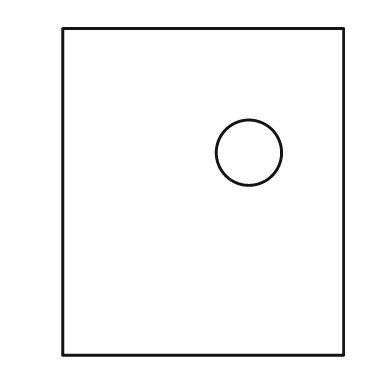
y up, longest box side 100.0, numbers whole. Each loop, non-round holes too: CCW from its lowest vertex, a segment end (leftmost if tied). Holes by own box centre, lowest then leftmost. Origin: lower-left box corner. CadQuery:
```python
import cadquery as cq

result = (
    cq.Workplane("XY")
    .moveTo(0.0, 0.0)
    .lineTo(86.0, 0.0)
    .lineTo(86.0, 100.0)
    .lineTo(0.0, 100.0)
    .close()
    .moveTo(57.0, 62.0)
    .circle(10.0)
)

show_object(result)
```